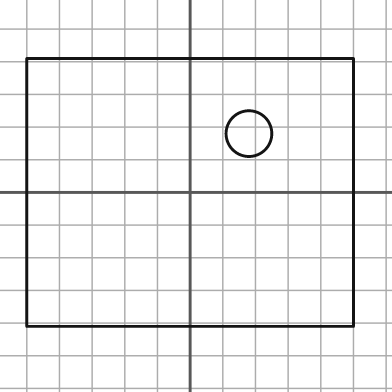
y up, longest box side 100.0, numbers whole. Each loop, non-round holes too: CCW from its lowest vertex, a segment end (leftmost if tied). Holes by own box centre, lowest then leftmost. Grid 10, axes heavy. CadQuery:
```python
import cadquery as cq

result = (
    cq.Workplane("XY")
    .moveTo(-50.0, -41.0)
    .lineTo(50.0, -41.0)
    .lineTo(50.0, 41.0)
    .lineTo(-50.0, 41.0)
    .close()
    .moveTo(18.0, 18.0)
    .circle(7.0)
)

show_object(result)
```